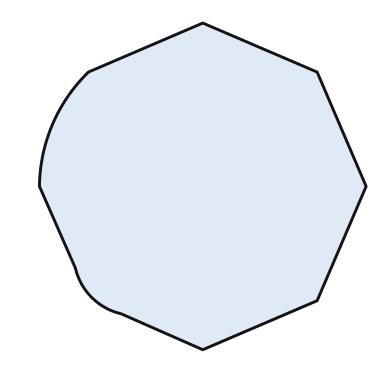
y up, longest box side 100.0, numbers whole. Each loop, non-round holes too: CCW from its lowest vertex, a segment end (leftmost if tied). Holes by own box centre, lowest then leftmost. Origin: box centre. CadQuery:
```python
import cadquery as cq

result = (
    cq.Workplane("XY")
    .moveTo(0.0, -50.0)
    .lineTo(35.0, -35.0)
    .lineTo(50.0, 0.0)
    .lineTo(35.0, 35.0)
    .lineTo(0.0, 50.0)
    .lineTo(-35.0, 35.0)
    .threePointArc((-46.0, 19.0), (-50.0, 0.0))
    .lineTo(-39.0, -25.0)
    .threePointArc((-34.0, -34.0), (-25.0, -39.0))
    .close()
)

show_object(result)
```